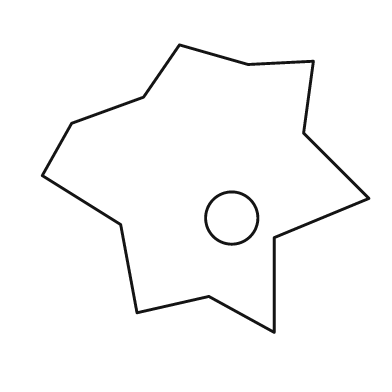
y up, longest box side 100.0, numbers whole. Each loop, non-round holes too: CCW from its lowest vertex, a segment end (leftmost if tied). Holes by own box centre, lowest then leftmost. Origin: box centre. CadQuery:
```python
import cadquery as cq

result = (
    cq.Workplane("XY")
    .moveTo(21.0, -44.0)
    .lineTo(21.0, -15.0)
    .lineTo(50.0, -3.0)
    .lineTo(30.0, 17.0)
    .lineTo(33.0, 39.0)
    .lineTo(13.0, 38.0)
    .lineTo(-8.0, 44.0)
    .lineTo(-19.0, 28.0)
    .lineTo(-41.0, 20.0)
    .lineTo(-50.0, 4.0)
    .lineTo(-26.0, -11.0)
    .lineTo(-21.0, -38.0)
    .lineTo(1.0, -33.0)
    .close()
    .moveTo(8.0, -9.0)
    .circle(8.0)
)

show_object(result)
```